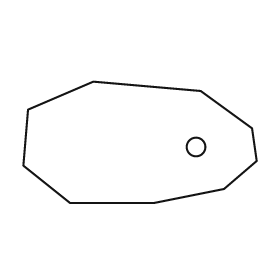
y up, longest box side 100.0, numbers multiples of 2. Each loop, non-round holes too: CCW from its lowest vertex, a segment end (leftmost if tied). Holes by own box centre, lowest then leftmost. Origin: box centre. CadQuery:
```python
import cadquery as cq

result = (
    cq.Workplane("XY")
    .moveTo(-30.0, -26.0)
    .lineTo(6.0, -26.0)
    .lineTo(36.0, -20.0)
    .lineTo(50.0, -8.0)
    .lineTo(48.0, 6.0)
    .lineTo(26.0, 22.0)
    .lineTo(-20.0, 26.0)
    .lineTo(-48.0, 14.0)
    .lineTo(-50.0, -10.0)
    .close()
    .moveTo(24.0, -2.0)
    .circle(4.0)
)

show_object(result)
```